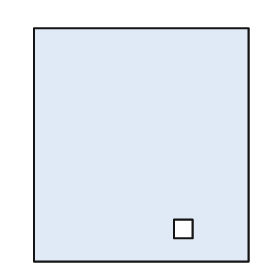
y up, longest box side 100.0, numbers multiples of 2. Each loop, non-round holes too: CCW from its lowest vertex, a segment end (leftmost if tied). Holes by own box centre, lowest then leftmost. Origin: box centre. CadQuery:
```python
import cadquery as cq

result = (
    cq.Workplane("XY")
    .moveTo(-46.0, -50.0)
    .lineTo(46.0, -50.0)
    .lineTo(46.0, 50.0)
    .lineTo(-46.0, 50.0)
    .close()
    .moveTo(14.0, -40.0)
    .lineTo(22.0, -40.0)
    .lineTo(22.0, -32.0)
    .lineTo(14.0, -32.0)
    .close()
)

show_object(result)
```